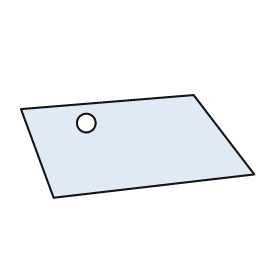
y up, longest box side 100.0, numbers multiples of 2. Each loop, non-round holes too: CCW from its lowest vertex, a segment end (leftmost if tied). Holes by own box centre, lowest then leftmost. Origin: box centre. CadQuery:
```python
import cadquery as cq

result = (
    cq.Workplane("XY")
    .moveTo(-36.0, -22.0)
    .lineTo(50.0, -12.0)
    .lineTo(24.0, 22.0)
    .lineTo(-50.0, 16.0)
    .close()
    .moveTo(-22.0, 10.0)
    .circle(4.0)
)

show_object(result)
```